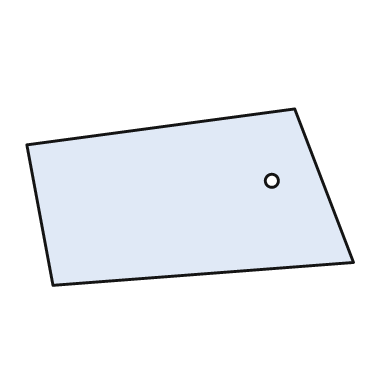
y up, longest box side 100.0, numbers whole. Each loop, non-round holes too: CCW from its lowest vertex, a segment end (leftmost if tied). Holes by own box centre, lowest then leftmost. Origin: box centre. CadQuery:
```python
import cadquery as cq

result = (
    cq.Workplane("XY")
    .moveTo(-42.0, -27.0)
    .lineTo(50.0, -20.0)
    .lineTo(32.0, 27.0)
    .lineTo(-50.0, 16.0)
    .close()
    .moveTo(25.0, 5.0)
    .circle(2.0)
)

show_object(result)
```